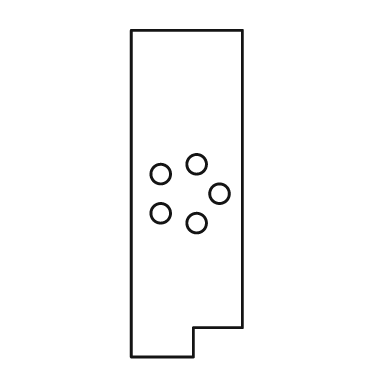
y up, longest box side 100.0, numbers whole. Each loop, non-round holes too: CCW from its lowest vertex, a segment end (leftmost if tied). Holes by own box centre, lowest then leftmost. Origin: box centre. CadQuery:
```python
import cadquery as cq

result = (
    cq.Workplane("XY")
    .moveTo(-17.0, -50.0)
    .lineTo(2.0, -50.0)
    .lineTo(2.0, -41.0)
    .lineTo(17.0, -41.0)
    .lineTo(17.0, 50.0)
    .lineTo(-17.0, 50.0)
    .close()
    .moveTo(3.0, -9.0)
    .circle(3.0)
    .moveTo(-8.0, -6.0)
    .circle(3.0)
    .moveTo(10.0, 0.0)
    .circle(3.0)
    .moveTo(-8.0, 6.0)
    .circle(3.0)
    .moveTo(3.0, 9.0)
    .circle(3.0)
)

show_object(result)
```